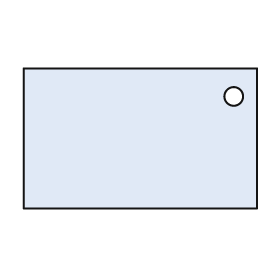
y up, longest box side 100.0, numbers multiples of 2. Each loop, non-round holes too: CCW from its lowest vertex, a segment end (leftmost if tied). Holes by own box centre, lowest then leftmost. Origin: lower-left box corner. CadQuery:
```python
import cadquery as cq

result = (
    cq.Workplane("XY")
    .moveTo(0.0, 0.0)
    .lineTo(100.0, 0.0)
    .lineTo(100.0, 60.0)
    .lineTo(0.0, 60.0)
    .close()
    .moveTo(90.0, 48.0)
    .circle(4.0)
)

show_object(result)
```